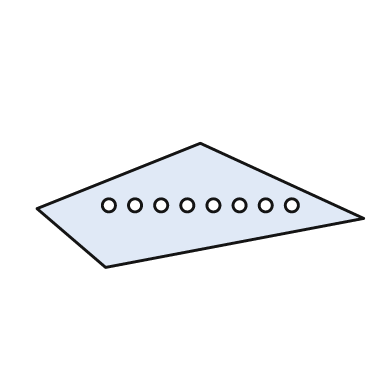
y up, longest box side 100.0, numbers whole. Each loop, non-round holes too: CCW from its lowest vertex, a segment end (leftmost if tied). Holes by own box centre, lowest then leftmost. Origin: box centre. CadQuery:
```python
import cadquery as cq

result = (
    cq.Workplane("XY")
    .moveTo(-29.0, -19.0)
    .lineTo(50.0, -4.0)
    .lineTo(0.0, 19.0)
    .lineTo(-50.0, -1.0)
    .close()
    .moveTo(-28.0, 0.0)
    .circle(2.0)
    .moveTo(-20.0, 0.0)
    .circle(2.0)
    .moveTo(-12.0, 0.0)
    .circle(2.0)
    .moveTo(-4.0, 0.0)
    .circle(2.0)
    .moveTo(4.0, 0.0)
    .circle(2.0)
    .moveTo(12.0, 0.0)
    .circle(2.0)
    .moveTo(20.0, 0.0)
    .circle(2.0)
    .moveTo(28.0, 0.0)
    .circle(2.0)
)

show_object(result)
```